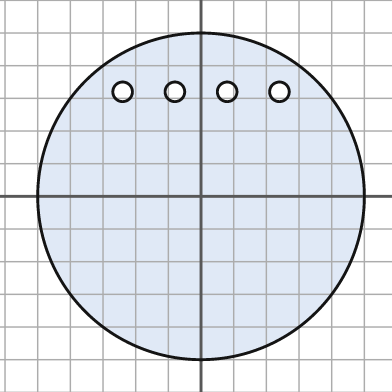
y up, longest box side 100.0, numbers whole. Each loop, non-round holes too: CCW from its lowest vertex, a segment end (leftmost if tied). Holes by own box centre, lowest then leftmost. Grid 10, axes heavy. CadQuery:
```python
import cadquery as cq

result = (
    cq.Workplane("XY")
    .moveTo(0.0, 0.0)
    .circle(50.0)
    .moveTo(-24.0, 32.0)
    .circle(3.0)
    .moveTo(-8.0, 32.0)
    .circle(3.0)
    .moveTo(8.0, 32.0)
    .circle(3.0)
    .moveTo(24.0, 32.0)
    .circle(3.0)
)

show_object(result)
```